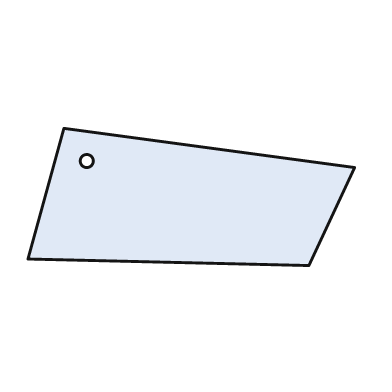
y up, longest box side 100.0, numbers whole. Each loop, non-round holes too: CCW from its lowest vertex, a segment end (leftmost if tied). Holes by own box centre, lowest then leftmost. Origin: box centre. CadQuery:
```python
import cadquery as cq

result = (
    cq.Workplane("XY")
    .moveTo(36.0, -21.0)
    .lineTo(50.0, 9.0)
    .lineTo(-39.0, 21.0)
    .lineTo(-50.0, -19.0)
    .close()
    .moveTo(-32.0, 11.0)
    .circle(2.0)
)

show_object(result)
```